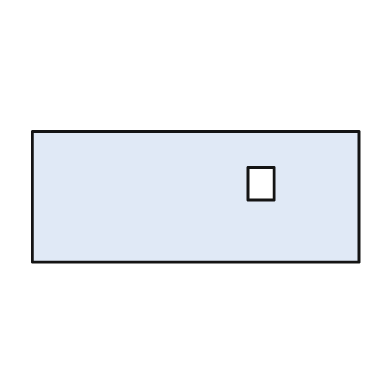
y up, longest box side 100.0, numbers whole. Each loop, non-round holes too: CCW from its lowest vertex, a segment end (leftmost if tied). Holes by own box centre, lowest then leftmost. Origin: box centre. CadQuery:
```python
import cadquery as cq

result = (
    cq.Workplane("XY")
    .moveTo(-50.0, -20.0)
    .lineTo(50.0, -20.0)
    .lineTo(50.0, 20.0)
    .lineTo(-50.0, 20.0)
    .close()
    .moveTo(16.0, -1.0)
    .lineTo(24.0, -1.0)
    .lineTo(24.0, 9.0)
    .lineTo(16.0, 9.0)
    .close()
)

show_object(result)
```